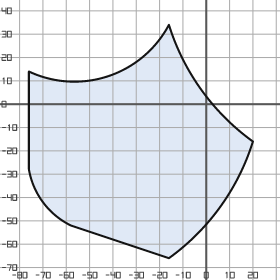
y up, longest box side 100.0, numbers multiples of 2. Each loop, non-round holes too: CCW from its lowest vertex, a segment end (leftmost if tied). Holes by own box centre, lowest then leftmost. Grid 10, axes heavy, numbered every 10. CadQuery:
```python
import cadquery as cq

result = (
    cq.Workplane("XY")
    .moveTo(-16.0, -66.0)
    .threePointArc((6.0, -44.0), (20.0, -16.0))
    .threePointArc((-2.0, 6.0), (-16.0, 34.0))
    .threePointArc((-42.0, 12.0), (-76.0, 14.0))
    .lineTo(-76.0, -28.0)
    .threePointArc((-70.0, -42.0), (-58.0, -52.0))
    .close()
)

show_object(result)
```